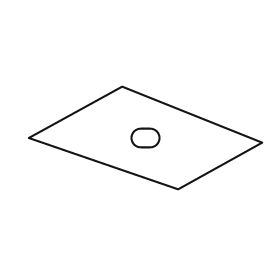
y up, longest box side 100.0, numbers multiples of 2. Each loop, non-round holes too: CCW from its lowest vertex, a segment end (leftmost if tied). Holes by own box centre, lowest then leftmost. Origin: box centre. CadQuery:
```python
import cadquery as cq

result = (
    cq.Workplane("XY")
    .moveTo(14.0, -22.0)
    .lineTo(50.0, -2.0)
    .lineTo(-10.0, 22.0)
    .lineTo(-50.0, 0.0)
    .close()
    .moveTo(-2.0, -4.0)
    .lineTo(2.0, -4.0)
    .threePointArc((6.0, 0.0), (2.0, 4.0))
    .lineTo(-2.0, 4.0)
    .threePointArc((-6.0, 0.0), (-2.0, -4.0))
    .close()
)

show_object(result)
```